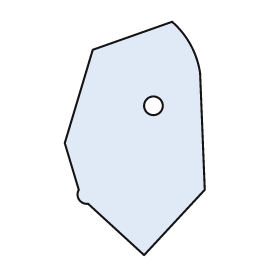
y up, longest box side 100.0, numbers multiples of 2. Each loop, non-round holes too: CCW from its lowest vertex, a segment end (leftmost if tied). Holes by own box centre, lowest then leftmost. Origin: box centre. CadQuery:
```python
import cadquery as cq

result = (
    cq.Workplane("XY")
    .moveTo(4.0, -50.0)
    .lineTo(30.0, -22.0)
    .lineTo(28.0, 28.0)
    .threePointArc((24.0, 40.0), (16.0, 50.0))
    .lineTo(-18.0, 38.0)
    .lineTo(-30.0, -2.0)
    .lineTo(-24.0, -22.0)
    .threePointArc((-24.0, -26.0), (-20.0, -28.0))
    .close()
    .moveTo(8.0, 14.0)
    .circle(4.0)
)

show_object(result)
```